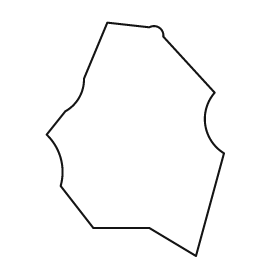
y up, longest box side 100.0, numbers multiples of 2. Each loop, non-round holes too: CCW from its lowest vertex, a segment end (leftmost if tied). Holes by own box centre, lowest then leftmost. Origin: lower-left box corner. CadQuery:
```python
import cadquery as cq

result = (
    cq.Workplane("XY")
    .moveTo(64.0, 0.0)
    .lineTo(76.0, 44.0)
    .threePointArc((68.0, 56.0), (72.0, 70.0))
    .lineTo(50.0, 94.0)
    .threePointArc((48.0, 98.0), (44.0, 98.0))
    .lineTo(26.0, 100.0)
    .lineTo(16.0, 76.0)
    .threePointArc((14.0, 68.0), (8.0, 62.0))
    .lineTo(0.0, 52.0)
    .threePointArc((6.0, 42.0), (6.0, 30.0))
    .lineTo(20.0, 12.0)
    .lineTo(44.0, 12.0)
    .close()
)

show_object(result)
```